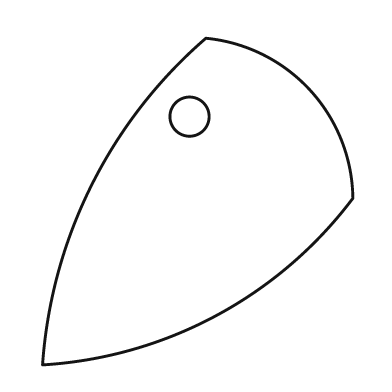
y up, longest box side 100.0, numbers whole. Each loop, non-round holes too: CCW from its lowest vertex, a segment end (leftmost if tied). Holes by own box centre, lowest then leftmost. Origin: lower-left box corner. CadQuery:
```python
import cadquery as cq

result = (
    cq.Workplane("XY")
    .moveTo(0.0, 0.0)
    .threePointArc((53.0, 15.0), (95.0, 51.0))
    .threePointArc((82.0, 84.0), (50.0, 100.0))
    .threePointArc((15.0, 55.0), (0.0, 0.0))
    .close()
    .moveTo(45.0, 76.0)
    .circle(6.0)
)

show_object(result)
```